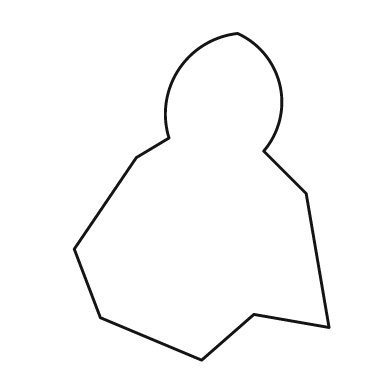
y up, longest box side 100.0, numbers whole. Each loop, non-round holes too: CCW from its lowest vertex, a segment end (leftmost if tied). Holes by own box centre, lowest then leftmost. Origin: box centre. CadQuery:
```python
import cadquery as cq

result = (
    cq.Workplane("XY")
    .moveTo(0.0, -50.0)
    .lineTo(16.0, -36.0)
    .lineTo(39.0, -40.0)
    .lineTo(32.0, 1.0)
    .lineTo(19.0, 14.0)
    .threePointArc((24.0, 34.0), (11.0, 50.0))
    .threePointArc((-7.0, 39.0), (-10.0, 18.0))
    .lineTo(-20.0, 12.0)
    .lineTo(-39.0, -16.0)
    .lineTo(-31.0, -37.0)
    .close()
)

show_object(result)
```